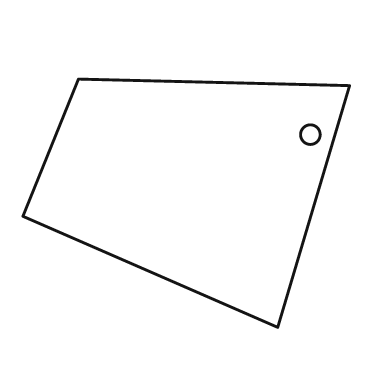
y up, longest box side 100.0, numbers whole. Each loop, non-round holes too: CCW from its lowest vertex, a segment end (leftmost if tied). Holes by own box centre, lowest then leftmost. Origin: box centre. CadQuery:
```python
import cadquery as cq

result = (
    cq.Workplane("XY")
    .moveTo(28.0, -38.0)
    .lineTo(50.0, 36.0)
    .lineTo(-33.0, 38.0)
    .lineTo(-50.0, -4.0)
    .close()
    .moveTo(38.0, 21.0)
    .circle(3.0)
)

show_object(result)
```